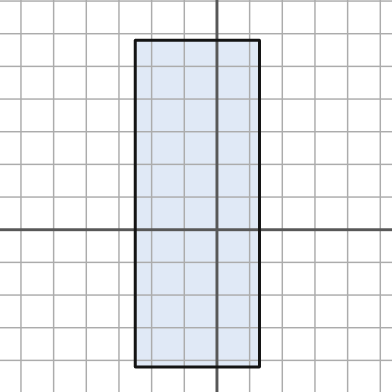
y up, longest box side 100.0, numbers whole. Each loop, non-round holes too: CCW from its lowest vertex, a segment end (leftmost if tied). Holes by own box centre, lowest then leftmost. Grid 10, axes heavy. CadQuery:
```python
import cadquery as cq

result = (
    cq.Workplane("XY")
    .moveTo(-25.0, -42.0)
    .lineTo(13.0, -42.0)
    .lineTo(13.0, 58.0)
    .lineTo(-25.0, 58.0)
    .close()
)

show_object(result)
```